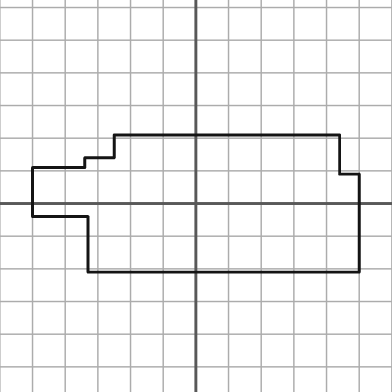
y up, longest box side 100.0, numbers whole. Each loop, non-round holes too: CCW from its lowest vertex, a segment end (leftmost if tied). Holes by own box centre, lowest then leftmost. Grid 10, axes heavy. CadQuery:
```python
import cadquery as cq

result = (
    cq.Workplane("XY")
    .moveTo(-33.0, -21.0)
    .lineTo(50.0, -21.0)
    .lineTo(50.0, 9.0)
    .lineTo(44.0, 9.0)
    .lineTo(44.0, 21.0)
    .lineTo(-25.0, 21.0)
    .lineTo(-25.0, 14.0)
    .lineTo(-34.0, 14.0)
    .lineTo(-34.0, 11.0)
    .lineTo(-50.0, 11.0)
    .lineTo(-50.0, -4.0)
    .lineTo(-33.0, -4.0)
    .close()
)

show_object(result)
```